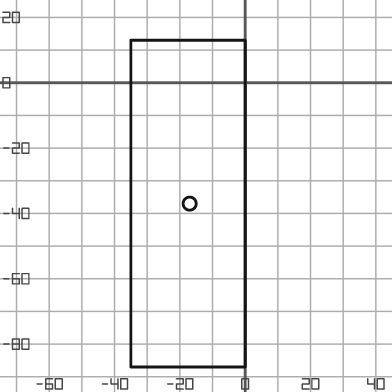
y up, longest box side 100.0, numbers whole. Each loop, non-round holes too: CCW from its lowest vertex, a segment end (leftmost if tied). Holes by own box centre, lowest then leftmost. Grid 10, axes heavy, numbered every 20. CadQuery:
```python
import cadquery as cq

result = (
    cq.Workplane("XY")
    .moveTo(-35.0, -87.0)
    .lineTo(0.0, -87.0)
    .lineTo(0.0, 13.0)
    .lineTo(-35.0, 13.0)
    .close()
    .moveTo(-17.0, -37.0)
    .circle(2.0)
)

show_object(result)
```